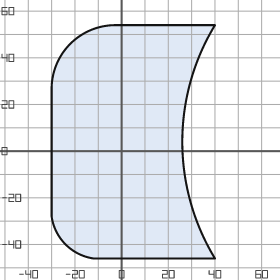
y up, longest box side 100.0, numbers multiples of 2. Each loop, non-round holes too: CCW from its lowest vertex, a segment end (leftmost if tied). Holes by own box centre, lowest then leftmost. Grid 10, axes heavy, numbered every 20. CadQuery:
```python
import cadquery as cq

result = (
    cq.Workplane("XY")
    .moveTo(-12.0, -46.0)
    .lineTo(40.0, -46.0)
    .threePointArc((26.0, 4.0), (40.0, 54.0))
    .lineTo(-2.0, 54.0)
    .threePointArc((-22.0, 46.0), (-30.0, 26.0))
    .lineTo(-30.0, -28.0)
    .threePointArc((-24.0, -40.0), (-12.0, -46.0))
    .close()
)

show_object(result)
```